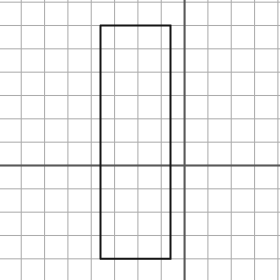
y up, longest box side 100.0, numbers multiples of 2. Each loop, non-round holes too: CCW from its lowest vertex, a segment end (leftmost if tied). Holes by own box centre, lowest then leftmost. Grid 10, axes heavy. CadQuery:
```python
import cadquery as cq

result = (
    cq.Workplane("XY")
    .moveTo(-36.0, -40.0)
    .lineTo(-6.0, -40.0)
    .lineTo(-6.0, 60.0)
    .lineTo(-36.0, 60.0)
    .close()
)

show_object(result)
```